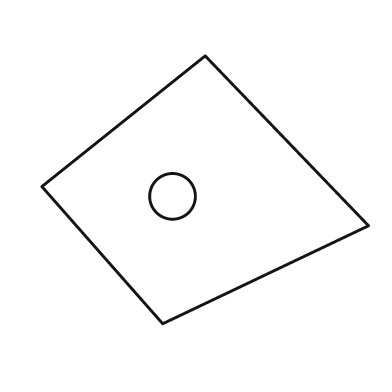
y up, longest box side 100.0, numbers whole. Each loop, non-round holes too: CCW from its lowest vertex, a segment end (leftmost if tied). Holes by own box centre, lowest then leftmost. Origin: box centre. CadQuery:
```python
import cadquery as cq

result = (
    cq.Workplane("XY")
    .moveTo(-13.0, -41.0)
    .lineTo(50.0, -11.0)
    .lineTo(0.0, 41.0)
    .lineTo(-50.0, 1.0)
    .close()
    .moveTo(-10.0, -2.0)
    .circle(7.0)
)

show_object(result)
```